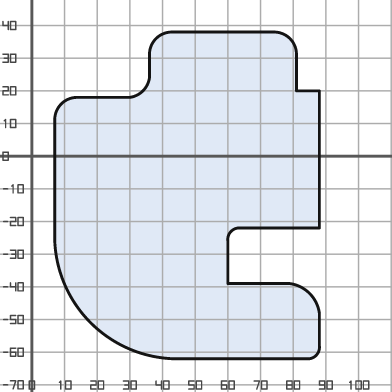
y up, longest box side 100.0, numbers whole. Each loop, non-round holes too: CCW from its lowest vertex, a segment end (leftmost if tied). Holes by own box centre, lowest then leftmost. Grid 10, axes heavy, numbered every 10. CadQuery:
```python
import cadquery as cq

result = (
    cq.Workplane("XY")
    .moveTo(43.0, -62.0)
    .lineTo(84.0, -62.0)
    .threePointArc((87.0, -61.0), (88.0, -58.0))
    .lineTo(88.0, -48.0)
    .threePointArc((85.0, -42.0), (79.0, -39.0))
    .lineTo(60.0, -39.0)
    .lineTo(60.0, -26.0)
    .threePointArc((61.0, -23.0), (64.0, -22.0))
    .lineTo(88.0, -22.0)
    .lineTo(88.0, 20.0)
    .lineTo(81.0, 20.0)
    .lineTo(81.0, 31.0)
    .threePointArc((79.0, 36.0), (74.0, 38.0))
    .lineTo(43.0, 38.0)
    .threePointArc((38.0, 36.0), (36.0, 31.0))
    .lineTo(36.0, 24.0)
    .threePointArc((34.0, 20.0), (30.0, 18.0))
    .lineTo(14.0, 18.0)
    .threePointArc((9.0, 16.0), (7.0, 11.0))
    .lineTo(7.0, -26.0)
    .threePointArc((18.0, -51.0), (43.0, -62.0))
    .close()
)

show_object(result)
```